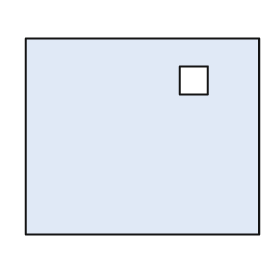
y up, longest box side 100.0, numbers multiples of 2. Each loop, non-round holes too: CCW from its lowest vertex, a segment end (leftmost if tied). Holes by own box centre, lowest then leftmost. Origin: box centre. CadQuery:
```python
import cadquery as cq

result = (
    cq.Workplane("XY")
    .moveTo(-50.0, -42.0)
    .lineTo(50.0, -42.0)
    .lineTo(50.0, 42.0)
    .lineTo(-50.0, 42.0)
    .close()
    .moveTo(16.0, 18.0)
    .lineTo(28.0, 18.0)
    .lineTo(28.0, 30.0)
    .lineTo(16.0, 30.0)
    .close()
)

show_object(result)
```